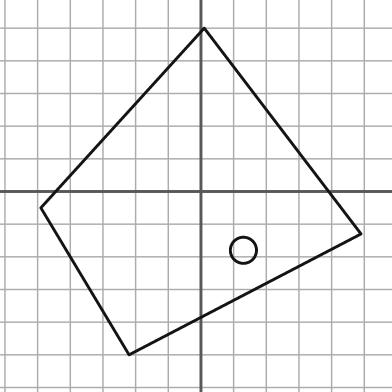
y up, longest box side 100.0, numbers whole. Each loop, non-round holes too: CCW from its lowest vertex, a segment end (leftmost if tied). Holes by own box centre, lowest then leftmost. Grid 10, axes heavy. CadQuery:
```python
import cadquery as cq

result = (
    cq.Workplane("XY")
    .moveTo(-22.0, -50.0)
    .lineTo(49.0, -13.0)
    .lineTo(1.0, 50.0)
    .lineTo(-49.0, -5.0)
    .close()
    .moveTo(13.0, -18.0)
    .circle(4.0)
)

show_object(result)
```